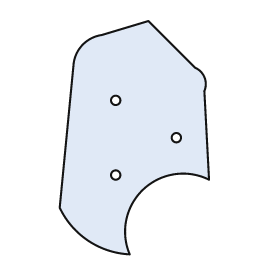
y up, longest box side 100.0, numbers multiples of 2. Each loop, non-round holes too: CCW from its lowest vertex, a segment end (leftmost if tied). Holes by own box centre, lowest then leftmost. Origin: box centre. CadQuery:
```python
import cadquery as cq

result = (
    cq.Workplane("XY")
    .moveTo(-2.0, -50.0)
    .threePointArc((4.0, -22.0), (32.0, -18.0))
    .lineTo(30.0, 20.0)
    .threePointArc((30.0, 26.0), (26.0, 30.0))
    .lineTo(6.0, 50.0)
    .lineTo(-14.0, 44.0)
    .threePointArc((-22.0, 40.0), (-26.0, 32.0))
    .lineTo(-32.0, -30.0)
    .threePointArc((-20.0, -44.0), (-2.0, -50.0))
    .close()
    .moveTo(-8.0, -16.0)
    .circle(2.0)
    .moveTo(18.0, 0.0)
    .circle(2.0)
    .moveTo(-8.0, 16.0)
    .circle(2.0)
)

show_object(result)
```